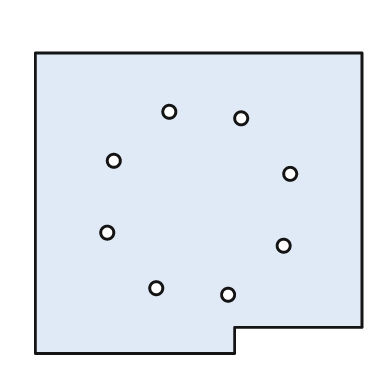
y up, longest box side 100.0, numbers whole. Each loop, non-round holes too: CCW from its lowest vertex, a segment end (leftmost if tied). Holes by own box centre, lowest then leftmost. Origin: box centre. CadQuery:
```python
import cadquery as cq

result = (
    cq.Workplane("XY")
    .moveTo(-50.0, -46.0)
    .lineTo(11.0, -46.0)
    .lineTo(11.0, -38.0)
    .lineTo(50.0, -38.0)
    .lineTo(50.0, 46.0)
    .lineTo(-50.0, 46.0)
    .close()
    .moveTo(9.0, -28.0)
    .circle(2.0)
    .moveTo(-13.0, -26.0)
    .circle(2.0)
    .moveTo(26.0, -13.0)
    .circle(2.0)
    .moveTo(-28.0, -9.0)
    .circle(2.0)
    .moveTo(28.0, 9.0)
    .circle(2.0)
    .moveTo(-26.0, 13.0)
    .circle(2.0)
    .moveTo(13.0, 26.0)
    .circle(2.0)
    .moveTo(-9.0, 28.0)
    .circle(2.0)
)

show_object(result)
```